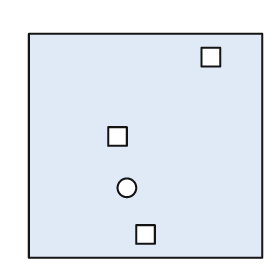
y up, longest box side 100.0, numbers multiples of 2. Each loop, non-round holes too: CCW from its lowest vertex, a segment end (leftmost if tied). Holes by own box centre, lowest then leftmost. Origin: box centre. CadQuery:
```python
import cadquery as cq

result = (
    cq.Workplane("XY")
    .moveTo(-50.0, -48.0)
    .lineTo(50.0, -48.0)
    .lineTo(50.0, 48.0)
    .lineTo(-50.0, 48.0)
    .close()
    .moveTo(-4.0, -42.0)
    .lineTo(4.0, -42.0)
    .lineTo(4.0, -34.0)
    .lineTo(-4.0, -34.0)
    .close()
    .moveTo(-8.0, -18.0)
    .circle(4.0)
    .moveTo(-16.0, 0.0)
    .lineTo(-8.0, 0.0)
    .lineTo(-8.0, 8.0)
    .lineTo(-16.0, 8.0)
    .close()
    .moveTo(24.0, 34.0)
    .lineTo(32.0, 34.0)
    .lineTo(32.0, 42.0)
    .lineTo(24.0, 42.0)
    .close()
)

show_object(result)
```